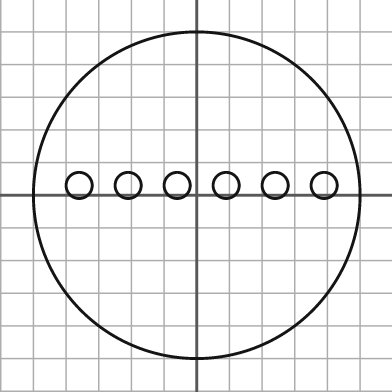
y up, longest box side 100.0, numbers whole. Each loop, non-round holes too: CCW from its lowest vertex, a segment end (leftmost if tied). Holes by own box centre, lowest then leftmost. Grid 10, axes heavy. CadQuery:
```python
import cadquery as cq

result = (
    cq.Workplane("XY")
    .moveTo(0.0, 0.0)
    .circle(50.0)
    .moveTo(-36.0, 3.0)
    .circle(4.0)
    .moveTo(-21.0, 3.0)
    .circle(4.0)
    .moveTo(-6.0, 3.0)
    .circle(4.0)
    .moveTo(9.0, 3.0)
    .circle(4.0)
    .moveTo(24.0, 3.0)
    .circle(4.0)
    .moveTo(39.0, 3.0)
    .circle(4.0)
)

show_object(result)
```